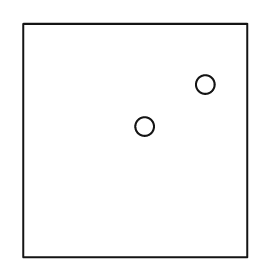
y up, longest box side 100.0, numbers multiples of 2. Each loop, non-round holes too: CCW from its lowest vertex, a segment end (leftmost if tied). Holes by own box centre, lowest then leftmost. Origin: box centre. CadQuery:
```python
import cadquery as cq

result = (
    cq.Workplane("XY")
    .moveTo(-48.0, -50.0)
    .lineTo(48.0, -50.0)
    .lineTo(48.0, 50.0)
    .lineTo(-48.0, 50.0)
    .close()
    .moveTo(4.0, 6.0)
    .circle(4.0)
    .moveTo(30.0, 24.0)
    .circle(4.0)
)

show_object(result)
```